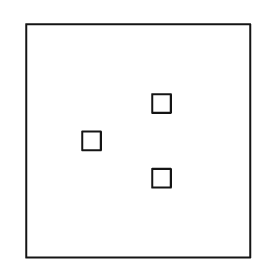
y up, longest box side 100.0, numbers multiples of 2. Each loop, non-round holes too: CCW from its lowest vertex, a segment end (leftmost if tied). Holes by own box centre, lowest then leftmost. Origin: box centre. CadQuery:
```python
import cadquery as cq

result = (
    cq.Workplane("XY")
    .moveTo(-48.0, -50.0)
    .lineTo(48.0, -50.0)
    .lineTo(48.0, 50.0)
    .lineTo(-48.0, 50.0)
    .close()
    .moveTo(6.0, -20.0)
    .lineTo(14.0, -20.0)
    .lineTo(14.0, -12.0)
    .lineTo(6.0, -12.0)
    .close()
    .moveTo(-24.0, -4.0)
    .lineTo(-16.0, -4.0)
    .lineTo(-16.0, 4.0)
    .lineTo(-24.0, 4.0)
    .close()
    .moveTo(6.0, 12.0)
    .lineTo(14.0, 12.0)
    .lineTo(14.0, 20.0)
    .lineTo(6.0, 20.0)
    .close()
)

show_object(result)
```